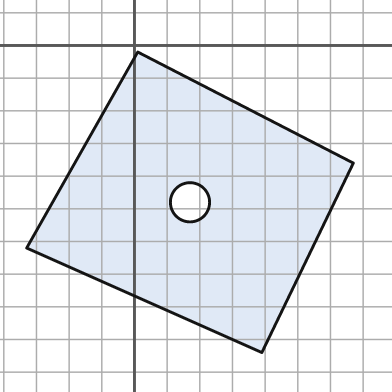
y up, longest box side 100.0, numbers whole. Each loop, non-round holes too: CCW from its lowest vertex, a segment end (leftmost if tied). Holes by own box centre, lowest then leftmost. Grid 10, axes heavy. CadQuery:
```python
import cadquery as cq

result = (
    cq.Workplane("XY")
    .moveTo(39.0, -94.0)
    .lineTo(67.0, -36.0)
    .lineTo(1.0, -2.0)
    .lineTo(-33.0, -62.0)
    .close()
    .moveTo(17.0, -48.0)
    .circle(6.0)
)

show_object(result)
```